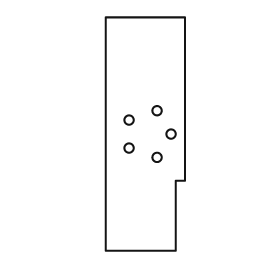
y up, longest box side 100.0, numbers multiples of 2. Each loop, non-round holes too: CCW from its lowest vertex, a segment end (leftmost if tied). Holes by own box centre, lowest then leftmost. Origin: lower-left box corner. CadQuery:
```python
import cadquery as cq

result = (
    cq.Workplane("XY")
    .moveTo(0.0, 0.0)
    .lineTo(30.0, 0.0)
    .lineTo(30.0, 30.0)
    .lineTo(34.0, 30.0)
    .lineTo(34.0, 100.0)
    .lineTo(0.0, 100.0)
    .close()
    .moveTo(22.0, 40.0)
    .circle(2.0)
    .moveTo(10.0, 44.0)
    .circle(2.0)
    .moveTo(28.0, 50.0)
    .circle(2.0)
    .moveTo(10.0, 56.0)
    .circle(2.0)
    .moveTo(22.0, 60.0)
    .circle(2.0)
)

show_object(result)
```